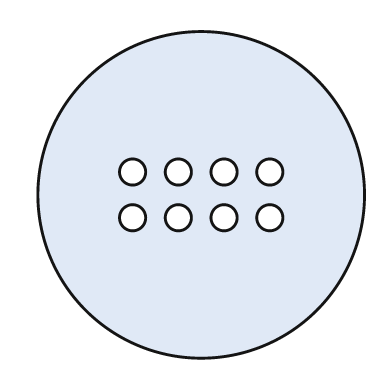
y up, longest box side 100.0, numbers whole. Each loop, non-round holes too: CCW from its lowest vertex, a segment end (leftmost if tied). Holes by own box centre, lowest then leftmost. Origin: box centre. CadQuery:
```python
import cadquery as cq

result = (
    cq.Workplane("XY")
    .moveTo(0.0, 0.0)
    .circle(50.0)
    .moveTo(-21.0, -7.0)
    .circle(4.0)
    .moveTo(-7.0, -7.0)
    .circle(4.0)
    .moveTo(7.0, -7.0)
    .circle(4.0)
    .moveTo(21.0, -7.0)
    .circle(4.0)
    .moveTo(-21.0, 7.0)
    .circle(4.0)
    .moveTo(-7.0, 7.0)
    .circle(4.0)
    .moveTo(7.0, 7.0)
    .circle(4.0)
    .moveTo(21.0, 7.0)
    .circle(4.0)
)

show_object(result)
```